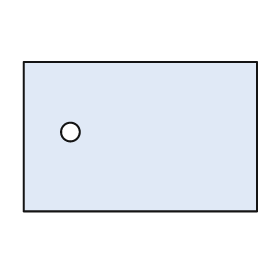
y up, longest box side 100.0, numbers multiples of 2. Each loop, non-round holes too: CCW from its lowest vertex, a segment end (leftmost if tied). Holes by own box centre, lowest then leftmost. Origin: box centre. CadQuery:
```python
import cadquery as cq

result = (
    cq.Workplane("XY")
    .moveTo(-50.0, -32.0)
    .lineTo(50.0, -32.0)
    .lineTo(50.0, 32.0)
    .lineTo(-50.0, 32.0)
    .close()
    .moveTo(-30.0, 2.0)
    .circle(4.0)
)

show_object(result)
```